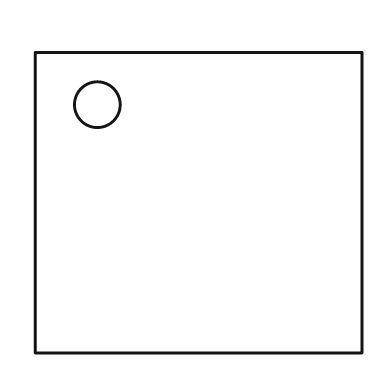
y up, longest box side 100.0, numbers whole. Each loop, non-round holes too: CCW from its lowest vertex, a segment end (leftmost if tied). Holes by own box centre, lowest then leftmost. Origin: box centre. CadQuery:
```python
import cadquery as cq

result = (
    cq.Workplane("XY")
    .moveTo(-50.0, -46.0)
    .lineTo(50.0, -46.0)
    .lineTo(50.0, 46.0)
    .lineTo(-50.0, 46.0)
    .close()
    .moveTo(-31.0, 30.0)
    .circle(7.0)
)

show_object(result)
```